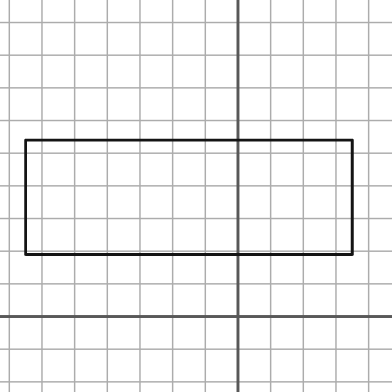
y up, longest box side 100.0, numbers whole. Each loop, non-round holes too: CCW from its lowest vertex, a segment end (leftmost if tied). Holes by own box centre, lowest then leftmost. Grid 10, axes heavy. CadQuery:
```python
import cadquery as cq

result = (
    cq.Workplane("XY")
    .moveTo(-65.0, 19.0)
    .lineTo(35.0, 19.0)
    .lineTo(35.0, 54.0)
    .lineTo(-65.0, 54.0)
    .close()
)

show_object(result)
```